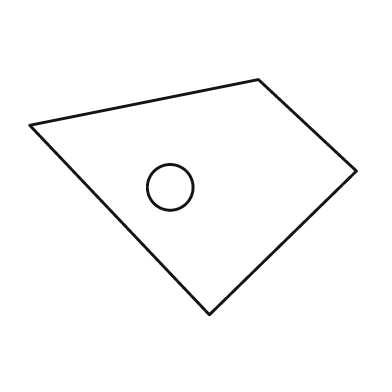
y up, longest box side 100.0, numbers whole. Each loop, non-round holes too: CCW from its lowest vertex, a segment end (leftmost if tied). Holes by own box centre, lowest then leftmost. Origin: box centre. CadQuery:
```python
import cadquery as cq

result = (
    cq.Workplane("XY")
    .moveTo(5.0, -36.0)
    .lineTo(50.0, 8.0)
    .lineTo(20.0, 36.0)
    .lineTo(-50.0, 22.0)
    .close()
    .moveTo(-7.0, 3.0)
    .circle(7.0)
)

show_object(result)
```